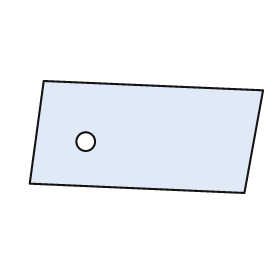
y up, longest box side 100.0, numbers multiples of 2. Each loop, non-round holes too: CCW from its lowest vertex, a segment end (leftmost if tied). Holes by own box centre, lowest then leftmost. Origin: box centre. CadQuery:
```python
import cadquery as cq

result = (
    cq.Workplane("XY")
    .moveTo(42.0, -24.0)
    .lineTo(50.0, 20.0)
    .lineTo(-44.0, 24.0)
    .lineTo(-50.0, -20.0)
    .close()
    .moveTo(-26.0, -2.0)
    .circle(4.0)
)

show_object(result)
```